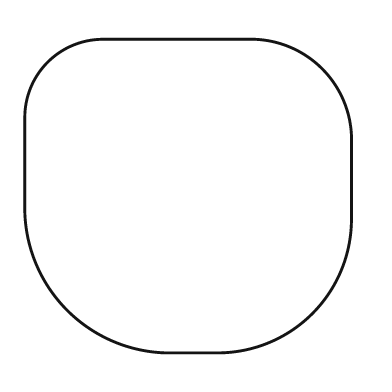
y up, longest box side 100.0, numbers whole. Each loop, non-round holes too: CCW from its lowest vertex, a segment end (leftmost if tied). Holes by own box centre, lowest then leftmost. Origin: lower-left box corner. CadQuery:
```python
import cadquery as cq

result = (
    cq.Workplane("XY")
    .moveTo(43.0, 0.0)
    .lineTo(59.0, 0.0)
    .threePointArc((88.0, 12.0), (100.0, 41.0))
    .lineTo(100.0, 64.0)
    .threePointArc((91.0, 87.0), (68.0, 96.0))
    .lineTo(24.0, 96.0)
    .threePointArc((7.0, 89.0), (0.0, 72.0))
    .lineTo(0.0, 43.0)
    .threePointArc((13.0, 13.0), (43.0, 0.0))
    .close()
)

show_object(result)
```